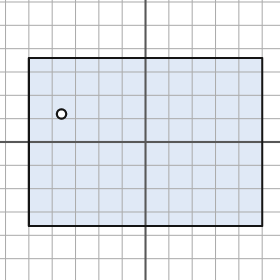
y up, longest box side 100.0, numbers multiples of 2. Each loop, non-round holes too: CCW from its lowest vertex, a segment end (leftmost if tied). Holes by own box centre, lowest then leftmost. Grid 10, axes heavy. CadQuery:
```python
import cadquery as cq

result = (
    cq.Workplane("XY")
    .moveTo(-50.0, -36.0)
    .lineTo(50.0, -36.0)
    .lineTo(50.0, 36.0)
    .lineTo(-50.0, 36.0)
    .close()
    .moveTo(-36.0, 12.0)
    .circle(2.0)
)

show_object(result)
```